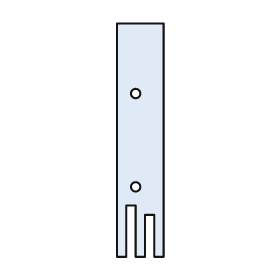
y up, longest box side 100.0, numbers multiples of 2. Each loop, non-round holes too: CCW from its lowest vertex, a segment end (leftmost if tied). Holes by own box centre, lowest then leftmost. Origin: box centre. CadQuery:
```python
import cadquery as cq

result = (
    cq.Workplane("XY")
    .moveTo(-10.0, -50.0)
    .lineTo(-6.0, -50.0)
    .lineTo(-6.0, -28.0)
    .lineTo(-2.0, -28.0)
    .lineTo(-2.0, -50.0)
    .lineTo(2.0, -50.0)
    .lineTo(2.0, -32.0)
    .lineTo(6.0, -32.0)
    .lineTo(6.0, -50.0)
    .lineTo(10.0, -50.0)
    .lineTo(10.0, 50.0)
    .lineTo(-10.0, 50.0)
    .close()
    .moveTo(-2.0, -20.0)
    .circle(2.0)
    .moveTo(-2.0, 20.0)
    .circle(2.0)
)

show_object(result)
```